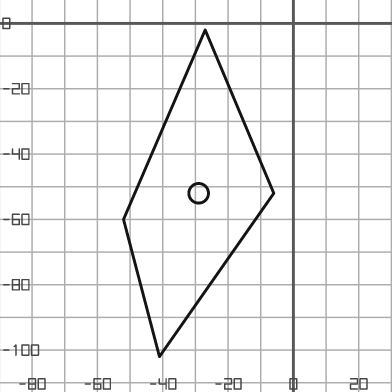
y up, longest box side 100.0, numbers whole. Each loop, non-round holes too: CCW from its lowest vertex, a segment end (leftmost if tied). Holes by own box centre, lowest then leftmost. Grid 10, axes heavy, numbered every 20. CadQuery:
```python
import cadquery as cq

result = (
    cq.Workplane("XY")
    .moveTo(-41.0, -102.0)
    .lineTo(-6.0, -52.0)
    .lineTo(-27.0, -2.0)
    .lineTo(-52.0, -60.0)
    .close()
    .moveTo(-29.0, -52.0)
    .circle(3.0)
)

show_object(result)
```